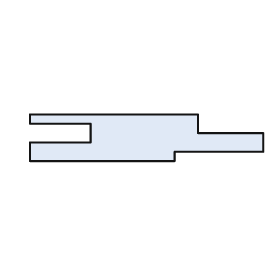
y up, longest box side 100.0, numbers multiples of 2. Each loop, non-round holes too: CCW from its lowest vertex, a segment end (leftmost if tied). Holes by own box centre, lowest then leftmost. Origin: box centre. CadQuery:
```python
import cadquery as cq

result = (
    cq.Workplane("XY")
    .moveTo(-50.0, -10.0)
    .lineTo(12.0, -10.0)
    .lineTo(12.0, -6.0)
    .lineTo(50.0, -6.0)
    .lineTo(50.0, 2.0)
    .lineTo(22.0, 2.0)
    .lineTo(22.0, 10.0)
    .lineTo(-50.0, 10.0)
    .lineTo(-50.0, 6.0)
    .lineTo(-24.0, 6.0)
    .lineTo(-24.0, -2.0)
    .lineTo(-50.0, -2.0)
    .close()
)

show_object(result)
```